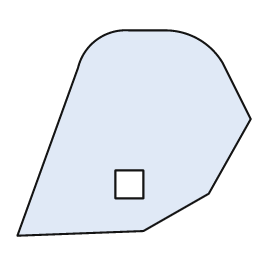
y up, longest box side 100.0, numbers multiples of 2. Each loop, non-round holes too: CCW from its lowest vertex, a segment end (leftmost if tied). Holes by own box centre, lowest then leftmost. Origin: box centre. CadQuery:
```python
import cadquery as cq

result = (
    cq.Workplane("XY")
    .moveTo(-50.0, -44.0)
    .lineTo(4.0, -42.0)
    .lineTo(32.0, -26.0)
    .lineTo(50.0, 6.0)
    .lineTo(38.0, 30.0)
    .threePointArc((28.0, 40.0), (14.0, 44.0))
    .lineTo(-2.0, 44.0)
    .threePointArc((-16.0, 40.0), (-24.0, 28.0))
    .close()
    .moveTo(-8.0, -28.0)
    .lineTo(4.0, -28.0)
    .lineTo(4.0, -16.0)
    .lineTo(-8.0, -16.0)
    .close()
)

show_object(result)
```